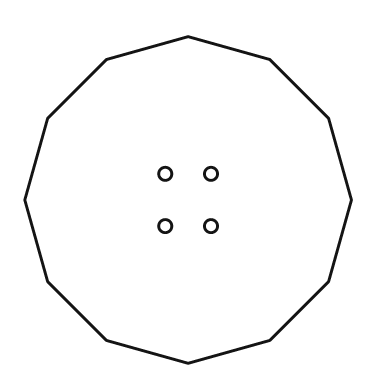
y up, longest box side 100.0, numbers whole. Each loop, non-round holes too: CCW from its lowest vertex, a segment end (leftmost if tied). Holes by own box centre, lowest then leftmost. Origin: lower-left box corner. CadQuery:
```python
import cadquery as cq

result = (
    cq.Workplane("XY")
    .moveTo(50.0, 0.0)
    .lineTo(75.0, 7.0)
    .lineTo(93.0, 25.0)
    .lineTo(100.0, 50.0)
    .lineTo(93.0, 75.0)
    .lineTo(75.0, 93.0)
    .lineTo(50.0, 100.0)
    .lineTo(25.0, 93.0)
    .lineTo(7.0, 75.0)
    .lineTo(0.0, 50.0)
    .lineTo(7.0, 25.0)
    .lineTo(25.0, 7.0)
    .close()
    .moveTo(43.0, 42.0)
    .circle(2.0)
    .moveTo(57.0, 42.0)
    .circle(2.0)
    .moveTo(43.0, 58.0)
    .circle(2.0)
    .moveTo(57.0, 58.0)
    .circle(2.0)
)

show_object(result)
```